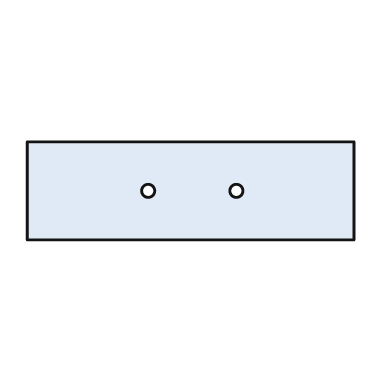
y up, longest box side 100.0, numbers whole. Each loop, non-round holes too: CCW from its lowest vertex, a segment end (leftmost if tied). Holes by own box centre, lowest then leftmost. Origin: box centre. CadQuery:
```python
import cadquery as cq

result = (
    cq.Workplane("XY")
    .moveTo(-50.0, -15.0)
    .lineTo(50.0, -15.0)
    .lineTo(50.0, 15.0)
    .lineTo(-50.0, 15.0)
    .close()
    .moveTo(-13.0, 0.0)
    .circle(2.0)
    .moveTo(14.0, 0.0)
    .circle(2.0)
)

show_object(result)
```